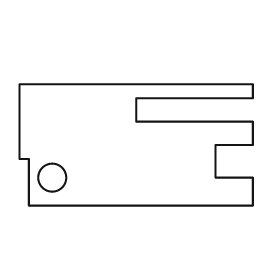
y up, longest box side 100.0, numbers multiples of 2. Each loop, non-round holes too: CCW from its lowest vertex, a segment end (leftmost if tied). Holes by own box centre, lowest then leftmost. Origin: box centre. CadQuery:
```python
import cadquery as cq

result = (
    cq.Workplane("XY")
    .moveTo(-46.0, -26.0)
    .lineTo(50.0, -26.0)
    .lineTo(50.0, -14.0)
    .lineTo(34.0, -14.0)
    .lineTo(34.0, 0.0)
    .lineTo(50.0, 0.0)
    .lineTo(50.0, 10.0)
    .lineTo(0.0, 10.0)
    .lineTo(0.0, 20.0)
    .lineTo(50.0, 20.0)
    .lineTo(50.0, 26.0)
    .lineTo(-50.0, 26.0)
    .lineTo(-50.0, -6.0)
    .lineTo(-46.0, -6.0)
    .close()
    .moveTo(-36.0, -14.0)
    .circle(6.0)
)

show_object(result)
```